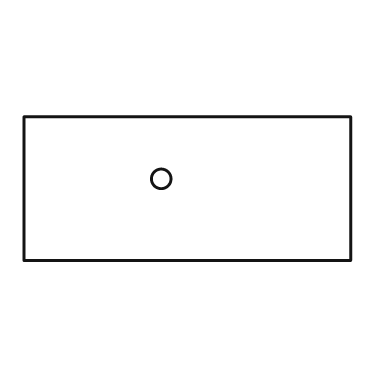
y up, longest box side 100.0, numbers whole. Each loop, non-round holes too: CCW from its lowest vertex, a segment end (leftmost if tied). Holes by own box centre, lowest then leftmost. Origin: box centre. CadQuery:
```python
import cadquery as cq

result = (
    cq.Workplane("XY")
    .moveTo(-50.0, -22.0)
    .lineTo(50.0, -22.0)
    .lineTo(50.0, 22.0)
    .lineTo(-50.0, 22.0)
    .close()
    .moveTo(-8.0, 3.0)
    .circle(3.0)
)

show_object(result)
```